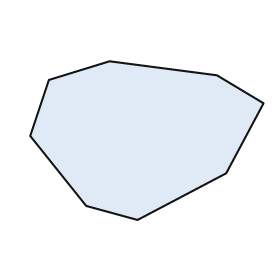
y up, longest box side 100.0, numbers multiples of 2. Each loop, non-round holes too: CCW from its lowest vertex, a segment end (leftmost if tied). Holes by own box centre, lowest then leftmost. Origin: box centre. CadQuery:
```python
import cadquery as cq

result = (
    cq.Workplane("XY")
    .moveTo(-4.0, -34.0)
    .lineTo(34.0, -14.0)
    .lineTo(50.0, 16.0)
    .lineTo(30.0, 28.0)
    .lineTo(-16.0, 34.0)
    .lineTo(-42.0, 26.0)
    .lineTo(-50.0, 2.0)
    .lineTo(-26.0, -28.0)
    .close()
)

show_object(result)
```